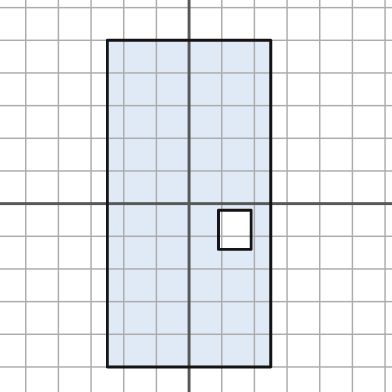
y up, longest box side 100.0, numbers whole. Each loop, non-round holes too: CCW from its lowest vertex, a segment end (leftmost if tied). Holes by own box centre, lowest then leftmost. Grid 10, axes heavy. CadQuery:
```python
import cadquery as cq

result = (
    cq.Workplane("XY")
    .moveTo(-25.0, -50.0)
    .lineTo(25.0, -50.0)
    .lineTo(25.0, 50.0)
    .lineTo(-25.0, 50.0)
    .close()
    .moveTo(9.0, -14.0)
    .lineTo(19.0, -14.0)
    .lineTo(19.0, -2.0)
    .lineTo(9.0, -2.0)
    .close()
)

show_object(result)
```